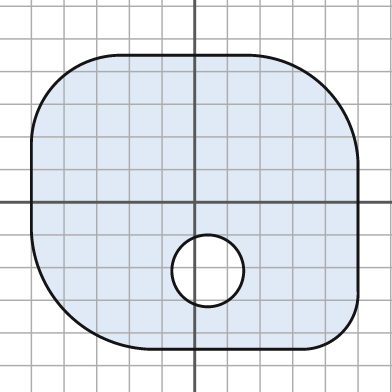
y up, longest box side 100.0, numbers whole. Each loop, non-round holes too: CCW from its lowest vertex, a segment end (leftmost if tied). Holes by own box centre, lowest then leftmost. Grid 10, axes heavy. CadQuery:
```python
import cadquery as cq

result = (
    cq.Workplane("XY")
    .moveTo(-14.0, -45.0)
    .lineTo(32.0, -45.0)
    .threePointArc((45.0, -40.0), (50.0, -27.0))
    .lineTo(50.0, 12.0)
    .threePointArc((40.0, 35.0), (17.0, 45.0))
    .lineTo(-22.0, 45.0)
    .threePointArc((-42.0, 37.0), (-50.0, 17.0))
    .lineTo(-50.0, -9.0)
    .threePointArc((-39.0, -34.0), (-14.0, -45.0))
    .close()
    .moveTo(4.0, -21.0)
    .circle(11.0)
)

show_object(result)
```